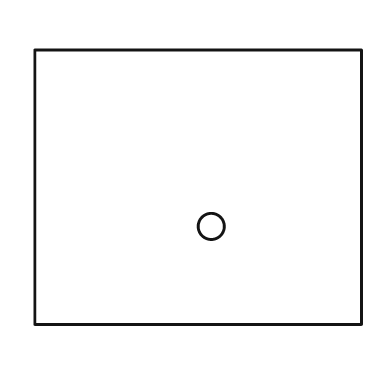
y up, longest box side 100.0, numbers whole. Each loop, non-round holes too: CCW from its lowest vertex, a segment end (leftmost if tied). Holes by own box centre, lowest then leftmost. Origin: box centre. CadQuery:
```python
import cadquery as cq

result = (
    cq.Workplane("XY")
    .moveTo(-50.0, -42.0)
    .lineTo(50.0, -42.0)
    .lineTo(50.0, 42.0)
    .lineTo(-50.0, 42.0)
    .close()
    .moveTo(4.0, -12.0)
    .circle(4.0)
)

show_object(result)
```